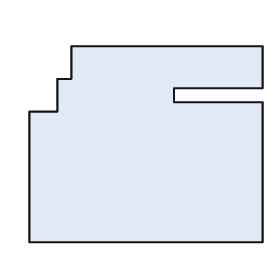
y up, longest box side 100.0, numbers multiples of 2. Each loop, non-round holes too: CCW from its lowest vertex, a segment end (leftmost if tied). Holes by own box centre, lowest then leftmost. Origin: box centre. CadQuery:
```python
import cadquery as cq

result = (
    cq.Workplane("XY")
    .moveTo(-50.0, -42.0)
    .lineTo(50.0, -42.0)
    .lineTo(50.0, 18.0)
    .lineTo(12.0, 18.0)
    .lineTo(12.0, 24.0)
    .lineTo(50.0, 24.0)
    .lineTo(50.0, 42.0)
    .lineTo(-32.0, 42.0)
    .lineTo(-32.0, 28.0)
    .lineTo(-38.0, 28.0)
    .lineTo(-38.0, 14.0)
    .lineTo(-50.0, 14.0)
    .close()
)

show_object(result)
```